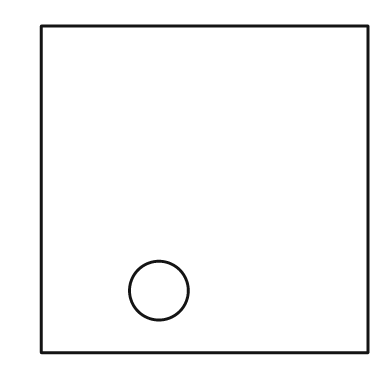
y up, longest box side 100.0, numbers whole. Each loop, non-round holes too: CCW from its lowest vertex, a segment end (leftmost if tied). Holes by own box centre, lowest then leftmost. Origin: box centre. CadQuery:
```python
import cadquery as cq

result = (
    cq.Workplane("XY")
    .moveTo(-50.0, -50.0)
    .lineTo(50.0, -50.0)
    .lineTo(50.0, 50.0)
    .lineTo(-50.0, 50.0)
    .close()
    .moveTo(-14.0, -31.0)
    .circle(9.0)
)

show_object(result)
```